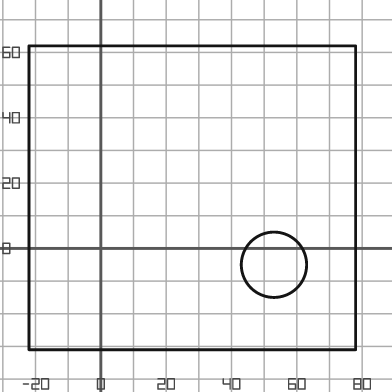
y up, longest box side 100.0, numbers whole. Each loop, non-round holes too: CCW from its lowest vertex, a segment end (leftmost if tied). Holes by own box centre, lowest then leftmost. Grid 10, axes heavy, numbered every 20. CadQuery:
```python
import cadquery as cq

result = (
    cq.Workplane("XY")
    .moveTo(-22.0, -31.0)
    .lineTo(78.0, -31.0)
    .lineTo(78.0, 62.0)
    .lineTo(-22.0, 62.0)
    .close()
    .moveTo(53.0, -5.0)
    .circle(10.0)
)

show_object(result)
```